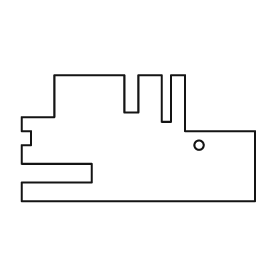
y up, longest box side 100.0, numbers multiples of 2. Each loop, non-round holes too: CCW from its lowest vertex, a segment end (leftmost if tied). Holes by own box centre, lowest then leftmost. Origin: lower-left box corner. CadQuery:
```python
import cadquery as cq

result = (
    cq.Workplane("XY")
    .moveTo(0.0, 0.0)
    .lineTo(100.0, 0.0)
    .lineTo(100.0, 30.0)
    .lineTo(70.0, 30.0)
    .lineTo(70.0, 54.0)
    .lineTo(64.0, 54.0)
    .lineTo(64.0, 34.0)
    .lineTo(60.0, 34.0)
    .lineTo(60.0, 54.0)
    .lineTo(50.0, 54.0)
    .lineTo(50.0, 38.0)
    .lineTo(44.0, 38.0)
    .lineTo(44.0, 54.0)
    .lineTo(14.0, 54.0)
    .lineTo(14.0, 36.0)
    .lineTo(0.0, 36.0)
    .lineTo(0.0, 30.0)
    .lineTo(4.0, 30.0)
    .lineTo(4.0, 24.0)
    .lineTo(0.0, 24.0)
    .lineTo(0.0, 16.0)
    .lineTo(30.0, 16.0)
    .lineTo(30.0, 8.0)
    .lineTo(0.0, 8.0)
    .close()
    .moveTo(76.0, 24.0)
    .circle(2.0)
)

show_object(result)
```